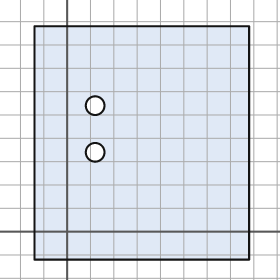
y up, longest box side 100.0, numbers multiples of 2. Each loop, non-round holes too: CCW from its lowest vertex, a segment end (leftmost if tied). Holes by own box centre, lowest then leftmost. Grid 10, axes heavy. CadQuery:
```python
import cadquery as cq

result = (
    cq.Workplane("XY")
    .moveTo(-14.0, -12.0)
    .lineTo(78.0, -12.0)
    .lineTo(78.0, 88.0)
    .lineTo(-14.0, 88.0)
    .close()
    .moveTo(12.0, 34.0)
    .circle(4.0)
    .moveTo(12.0, 54.0)
    .circle(4.0)
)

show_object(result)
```